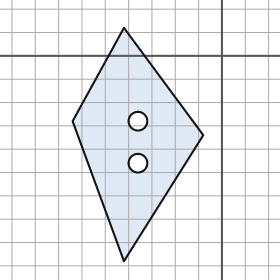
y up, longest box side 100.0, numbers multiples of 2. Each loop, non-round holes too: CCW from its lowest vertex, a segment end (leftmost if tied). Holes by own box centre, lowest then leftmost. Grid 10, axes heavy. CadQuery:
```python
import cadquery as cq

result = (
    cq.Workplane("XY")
    .moveTo(-42.0, -88.0)
    .lineTo(-8.0, -34.0)
    .lineTo(-42.0, 12.0)
    .lineTo(-64.0, -28.0)
    .close()
    .moveTo(-36.0, -46.0)
    .circle(4.0)
    .moveTo(-36.0, -28.0)
    .circle(4.0)
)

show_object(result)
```